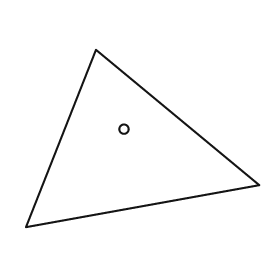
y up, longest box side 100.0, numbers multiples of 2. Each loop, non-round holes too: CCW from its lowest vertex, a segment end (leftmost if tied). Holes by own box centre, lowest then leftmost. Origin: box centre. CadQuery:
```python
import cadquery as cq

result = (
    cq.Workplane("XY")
    .moveTo(-50.0, -38.0)
    .lineTo(50.0, -20.0)
    .lineTo(-20.0, 38.0)
    .close()
    .moveTo(-8.0, 4.0)
    .circle(2.0)
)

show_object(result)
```